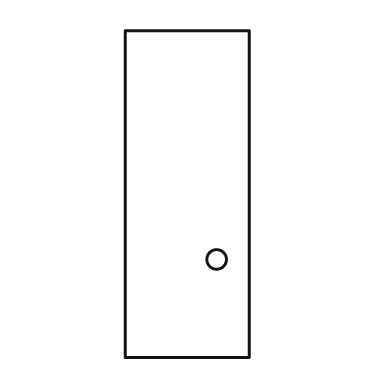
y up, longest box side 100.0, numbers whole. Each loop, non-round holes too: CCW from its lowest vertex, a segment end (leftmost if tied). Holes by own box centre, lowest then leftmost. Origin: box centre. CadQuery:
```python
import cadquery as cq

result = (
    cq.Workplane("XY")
    .moveTo(-19.0, -50.0)
    .lineTo(19.0, -50.0)
    .lineTo(19.0, 50.0)
    .lineTo(-19.0, 50.0)
    .close()
    .moveTo(9.0, -20.0)
    .circle(3.0)
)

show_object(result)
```